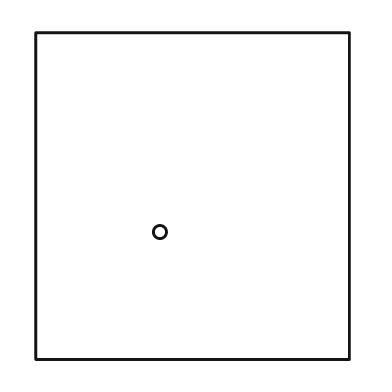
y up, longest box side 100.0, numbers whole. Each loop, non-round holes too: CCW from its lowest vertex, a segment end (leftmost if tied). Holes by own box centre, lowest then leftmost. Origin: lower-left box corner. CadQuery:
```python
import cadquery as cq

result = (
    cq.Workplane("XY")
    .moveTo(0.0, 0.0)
    .lineTo(96.0, 0.0)
    .lineTo(96.0, 100.0)
    .lineTo(0.0, 100.0)
    .close()
    .moveTo(38.0, 39.0)
    .circle(2.0)
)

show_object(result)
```